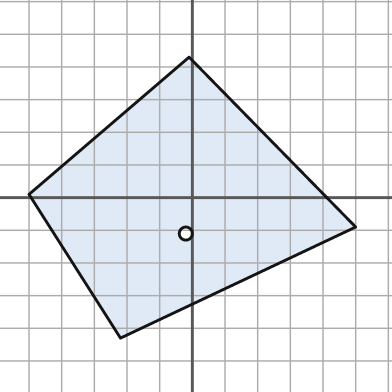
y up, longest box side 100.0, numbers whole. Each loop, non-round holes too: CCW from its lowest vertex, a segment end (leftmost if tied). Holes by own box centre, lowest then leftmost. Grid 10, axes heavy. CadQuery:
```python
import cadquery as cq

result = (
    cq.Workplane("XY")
    .moveTo(-22.0, -43.0)
    .lineTo(50.0, -9.0)
    .lineTo(-1.0, 43.0)
    .lineTo(-50.0, 1.0)
    .close()
    .moveTo(-2.0, -11.0)
    .circle(2.0)
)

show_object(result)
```